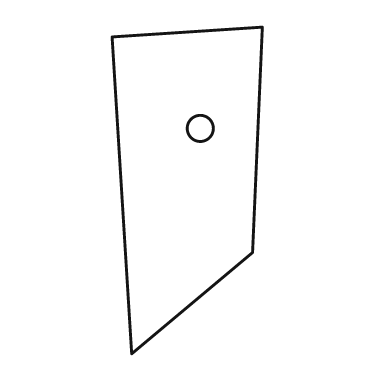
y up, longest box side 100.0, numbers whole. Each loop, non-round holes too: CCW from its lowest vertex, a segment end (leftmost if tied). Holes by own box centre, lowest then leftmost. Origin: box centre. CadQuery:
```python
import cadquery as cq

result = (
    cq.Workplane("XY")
    .moveTo(-17.0, -50.0)
    .lineTo(20.0, -19.0)
    .lineTo(23.0, 50.0)
    .lineTo(-23.0, 47.0)
    .close()
    .moveTo(4.0, 19.0)
    .circle(4.0)
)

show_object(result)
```